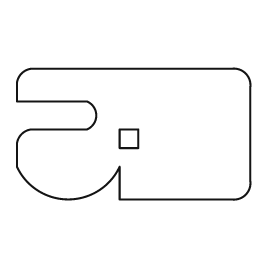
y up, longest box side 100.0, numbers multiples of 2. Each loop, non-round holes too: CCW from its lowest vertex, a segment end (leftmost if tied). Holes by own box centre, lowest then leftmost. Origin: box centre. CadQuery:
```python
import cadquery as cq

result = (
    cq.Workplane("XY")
    .moveTo(-6.0, -28.0)
    .lineTo(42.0, -28.0)
    .threePointArc((48.0, -26.0), (50.0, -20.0))
    .lineTo(50.0, 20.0)
    .threePointArc((48.0, 26.0), (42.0, 28.0))
    .lineTo(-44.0, 28.0)
    .threePointArc((-48.0, 26.0), (-50.0, 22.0))
    .lineTo(-50.0, 14.0)
    .lineTo(-20.0, 14.0)
    .threePointArc((-16.0, 8.0), (-20.0, 2.0))
    .lineTo(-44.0, 2.0)
    .threePointArc((-48.0, 0.0), (-50.0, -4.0))
    .lineTo(-50.0, -14.0)
    .threePointArc((-28.0, -28.0), (-6.0, -14.0))
    .close()
    .moveTo(-6.0, -6.0)
    .lineTo(2.0, -6.0)
    .lineTo(2.0, 2.0)
    .lineTo(-6.0, 2.0)
    .close()
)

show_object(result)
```